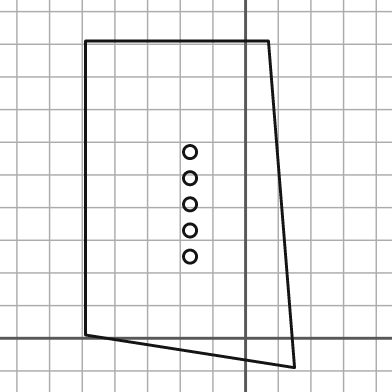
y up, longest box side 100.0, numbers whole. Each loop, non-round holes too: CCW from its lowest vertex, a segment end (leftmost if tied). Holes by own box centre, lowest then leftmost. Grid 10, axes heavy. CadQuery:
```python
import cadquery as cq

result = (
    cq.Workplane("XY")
    .moveTo(15.0, -9.0)
    .lineTo(7.0, 91.0)
    .lineTo(-49.0, 91.0)
    .lineTo(-49.0, 1.0)
    .close()
    .moveTo(-17.0, 25.0)
    .circle(2.0)
    .moveTo(-17.0, 33.0)
    .circle(2.0)
    .moveTo(-17.0, 41.0)
    .circle(2.0)
    .moveTo(-17.0, 49.0)
    .circle(2.0)
    .moveTo(-17.0, 57.0)
    .circle(2.0)
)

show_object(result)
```